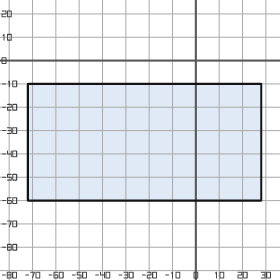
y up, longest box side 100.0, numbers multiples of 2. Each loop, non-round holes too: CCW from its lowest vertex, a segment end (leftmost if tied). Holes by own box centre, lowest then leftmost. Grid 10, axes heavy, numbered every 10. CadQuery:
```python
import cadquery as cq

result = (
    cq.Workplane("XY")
    .moveTo(-72.0, -60.0)
    .lineTo(28.0, -60.0)
    .lineTo(28.0, -10.0)
    .lineTo(-72.0, -10.0)
    .close()
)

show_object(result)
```